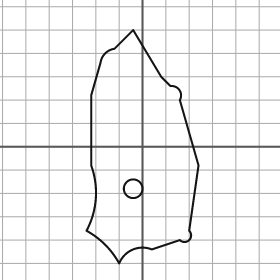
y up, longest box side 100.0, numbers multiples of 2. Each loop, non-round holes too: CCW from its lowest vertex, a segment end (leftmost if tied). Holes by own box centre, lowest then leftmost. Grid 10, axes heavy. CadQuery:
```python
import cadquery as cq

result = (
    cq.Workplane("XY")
    .moveTo(-10.0, -50.0)
    .threePointArc((-4.0, -44.0), (4.0, -44.0))
    .lineTo(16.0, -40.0)
    .threePointArc((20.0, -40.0), (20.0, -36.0))
    .lineTo(24.0, -8.0)
    .lineTo(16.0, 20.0)
    .threePointArc((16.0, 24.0), (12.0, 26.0))
    .lineTo(8.0, 30.0)
    .lineTo(-4.0, 50.0)
    .lineTo(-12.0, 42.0)
    .threePointArc((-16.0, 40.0), (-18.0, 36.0))
    .lineTo(-22.0, 22.0)
    .lineTo(-22.0, -8.0)
    .threePointArc((-20.0, -22.0), (-24.0, -36.0))
    .threePointArc((-16.0, -42.0), (-10.0, -50.0))
    .close()
    .moveTo(-4.0, -18.0)
    .circle(4.0)
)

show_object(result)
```